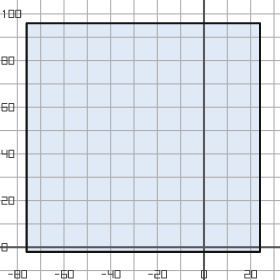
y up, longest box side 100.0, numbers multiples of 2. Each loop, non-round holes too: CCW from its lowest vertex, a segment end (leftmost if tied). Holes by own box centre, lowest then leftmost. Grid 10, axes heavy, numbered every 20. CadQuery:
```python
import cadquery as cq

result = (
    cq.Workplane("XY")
    .moveTo(-76.0, -2.0)
    .lineTo(24.0, -2.0)
    .lineTo(24.0, 96.0)
    .lineTo(-76.0, 96.0)
    .close()
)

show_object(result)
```